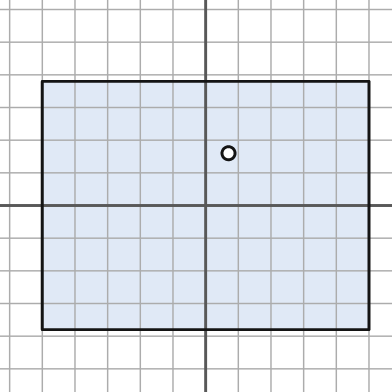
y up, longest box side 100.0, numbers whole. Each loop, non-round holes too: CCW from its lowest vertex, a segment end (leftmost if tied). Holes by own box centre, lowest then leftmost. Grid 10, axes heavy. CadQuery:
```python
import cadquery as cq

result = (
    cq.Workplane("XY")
    .moveTo(-50.0, -38.0)
    .lineTo(50.0, -38.0)
    .lineTo(50.0, 38.0)
    .lineTo(-50.0, 38.0)
    .close()
    .moveTo(7.0, 16.0)
    .circle(2.0)
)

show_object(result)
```